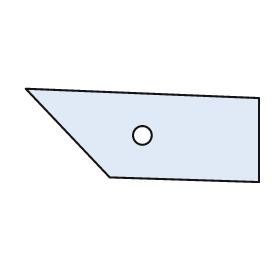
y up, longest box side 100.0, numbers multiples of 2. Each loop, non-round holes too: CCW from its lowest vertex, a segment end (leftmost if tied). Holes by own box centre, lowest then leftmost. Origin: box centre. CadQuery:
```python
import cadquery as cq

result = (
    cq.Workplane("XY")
    .moveTo(50.0, -20.0)
    .lineTo(50.0, 16.0)
    .lineTo(-50.0, 20.0)
    .lineTo(-14.0, -18.0)
    .close()
    .moveTo(0.0, 0.0)
    .circle(4.0)
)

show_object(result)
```